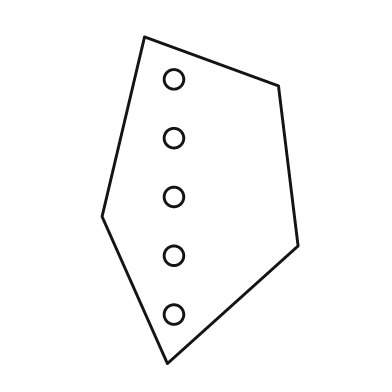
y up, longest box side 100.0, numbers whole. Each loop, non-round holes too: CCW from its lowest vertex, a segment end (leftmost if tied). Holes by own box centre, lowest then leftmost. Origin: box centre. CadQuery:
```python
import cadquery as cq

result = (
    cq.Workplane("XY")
    .moveTo(-10.0, -50.0)
    .lineTo(30.0, -14.0)
    .lineTo(24.0, 35.0)
    .lineTo(-17.0, 50.0)
    .lineTo(-30.0, -5.0)
    .close()
    .moveTo(-8.0, -35.0)
    .circle(3.0)
    .moveTo(-8.0, -17.0)
    .circle(3.0)
    .moveTo(-8.0, 1.0)
    .circle(3.0)
    .moveTo(-8.0, 19.0)
    .circle(3.0)
    .moveTo(-8.0, 37.0)
    .circle(3.0)
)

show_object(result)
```